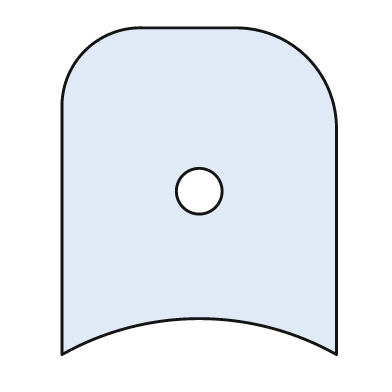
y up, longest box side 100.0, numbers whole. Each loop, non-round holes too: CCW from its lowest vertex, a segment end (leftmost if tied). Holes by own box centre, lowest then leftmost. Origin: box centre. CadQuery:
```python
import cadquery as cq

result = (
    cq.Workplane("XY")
    .moveTo(-42.0, -50.0)
    .threePointArc((0.0, -39.0), (42.0, -50.0))
    .lineTo(42.0, 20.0)
    .threePointArc((33.0, 41.0), (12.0, 50.0))
    .lineTo(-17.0, 50.0)
    .threePointArc((-35.0, 43.0), (-42.0, 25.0))
    .close()
    .moveTo(0.0, 0.0)
    .circle(7.0)
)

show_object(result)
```